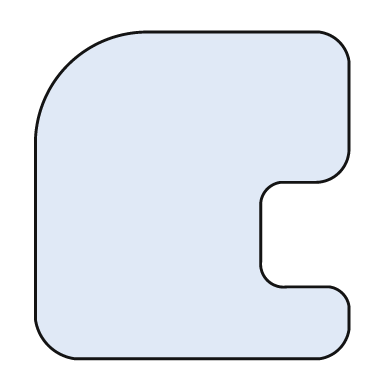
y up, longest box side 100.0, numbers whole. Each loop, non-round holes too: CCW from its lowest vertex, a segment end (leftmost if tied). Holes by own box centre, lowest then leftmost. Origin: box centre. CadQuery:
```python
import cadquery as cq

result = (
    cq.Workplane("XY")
    .moveTo(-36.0, -50.0)
    .lineTo(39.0, -50.0)
    .threePointArc((45.0, -47.0), (48.0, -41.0))
    .lineTo(48.0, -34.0)
    .threePointArc((46.0, -30.0), (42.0, -28.0))
    .lineTo(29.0, -28.0)
    .threePointArc((23.0, -26.0), (21.0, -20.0))
    .lineTo(21.0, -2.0)
    .threePointArc((23.0, 2.0), (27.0, 4.0))
    .lineTo(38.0, 4.0)
    .threePointArc((45.0, 7.0), (48.0, 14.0))
    .lineTo(48.0, 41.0)
    .threePointArc((45.0, 47.0), (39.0, 50.0))
    .lineTo(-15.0, 50.0)
    .threePointArc((-38.0, 40.0), (-48.0, 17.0))
    .lineTo(-48.0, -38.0)
    .threePointArc((-44.0, -46.0), (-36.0, -50.0))
    .close()
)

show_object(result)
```